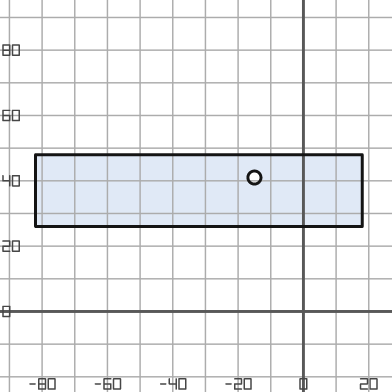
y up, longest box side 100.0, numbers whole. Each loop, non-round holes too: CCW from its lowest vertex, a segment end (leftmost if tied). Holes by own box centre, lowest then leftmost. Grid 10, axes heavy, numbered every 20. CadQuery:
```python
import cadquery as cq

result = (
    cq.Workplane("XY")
    .moveTo(-82.0, 26.0)
    .lineTo(18.0, 26.0)
    .lineTo(18.0, 48.0)
    .lineTo(-82.0, 48.0)
    .close()
    .moveTo(-15.0, 41.0)
    .circle(2.0)
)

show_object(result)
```